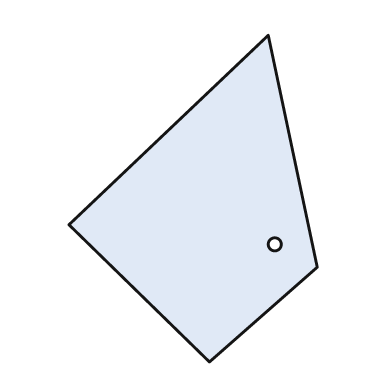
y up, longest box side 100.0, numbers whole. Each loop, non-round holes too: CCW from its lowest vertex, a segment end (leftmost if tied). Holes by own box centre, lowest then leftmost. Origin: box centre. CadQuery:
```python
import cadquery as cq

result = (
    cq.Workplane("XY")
    .moveTo(5.0, -50.0)
    .lineTo(38.0, -21.0)
    .lineTo(23.0, 50.0)
    .lineTo(-38.0, -8.0)
    .close()
    .moveTo(25.0, -14.0)
    .circle(2.0)
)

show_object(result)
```